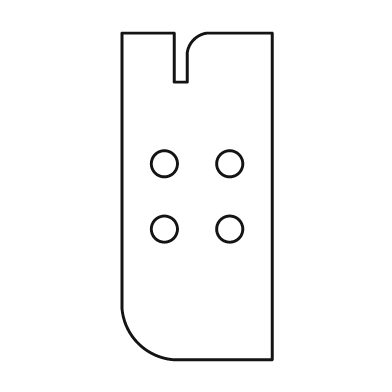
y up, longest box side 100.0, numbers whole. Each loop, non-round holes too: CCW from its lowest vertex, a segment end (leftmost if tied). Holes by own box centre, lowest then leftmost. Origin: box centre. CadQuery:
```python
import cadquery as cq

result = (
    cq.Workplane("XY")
    .moveTo(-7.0, -50.0)
    .lineTo(23.0, -50.0)
    .lineTo(23.0, 50.0)
    .lineTo(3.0, 50.0)
    .threePointArc((-1.0, 48.0), (-3.0, 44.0))
    .lineTo(-3.0, 35.0)
    .lineTo(-7.0, 35.0)
    .lineTo(-7.0, 50.0)
    .lineTo(-23.0, 50.0)
    .lineTo(-23.0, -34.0)
    .threePointArc((-18.0, -45.0), (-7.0, -50.0))
    .close()
    .moveTo(-10.0, -10.0)
    .circle(4.0)
    .moveTo(10.0, -10.0)
    .circle(4.0)
    .moveTo(-10.0, 10.0)
    .circle(4.0)
    .moveTo(10.0, 10.0)
    .circle(4.0)
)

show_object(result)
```